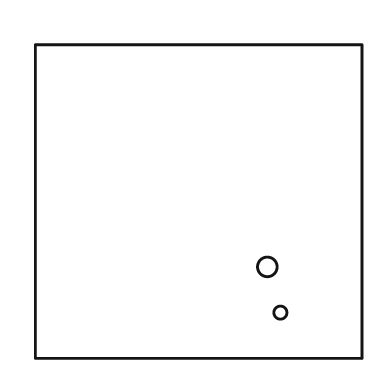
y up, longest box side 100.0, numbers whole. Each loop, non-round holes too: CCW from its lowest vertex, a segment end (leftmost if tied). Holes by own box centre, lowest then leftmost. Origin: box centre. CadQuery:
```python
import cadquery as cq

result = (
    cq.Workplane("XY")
    .moveTo(-50.0, -48.0)
    .lineTo(50.0, -48.0)
    .lineTo(50.0, 48.0)
    .lineTo(-50.0, 48.0)
    .close()
    .moveTo(25.0, -34.0)
    .circle(2.0)
    .moveTo(21.0, -20.0)
    .circle(3.0)
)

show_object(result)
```